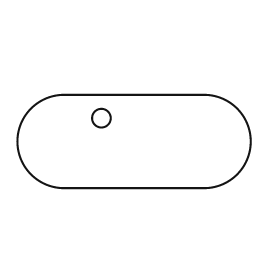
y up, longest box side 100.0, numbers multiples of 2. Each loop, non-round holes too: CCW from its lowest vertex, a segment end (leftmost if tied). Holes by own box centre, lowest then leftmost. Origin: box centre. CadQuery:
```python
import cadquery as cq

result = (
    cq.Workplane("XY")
    .moveTo(-30.0, -20.0)
    .lineTo(30.0, -20.0)
    .threePointArc((50.0, 0.0), (30.0, 20.0))
    .lineTo(-30.0, 20.0)
    .threePointArc((-50.0, 0.0), (-30.0, -20.0))
    .close()
    .moveTo(-14.0, 10.0)
    .circle(4.0)
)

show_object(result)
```